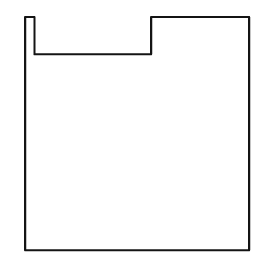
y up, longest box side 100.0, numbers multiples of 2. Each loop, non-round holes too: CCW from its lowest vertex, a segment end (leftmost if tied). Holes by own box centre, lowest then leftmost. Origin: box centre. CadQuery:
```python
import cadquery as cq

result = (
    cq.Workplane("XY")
    .moveTo(-48.0, -50.0)
    .lineTo(48.0, -50.0)
    .lineTo(48.0, 50.0)
    .lineTo(6.0, 50.0)
    .lineTo(6.0, 34.0)
    .lineTo(-44.0, 34.0)
    .lineTo(-44.0, 50.0)
    .lineTo(-48.0, 50.0)
    .close()
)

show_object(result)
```